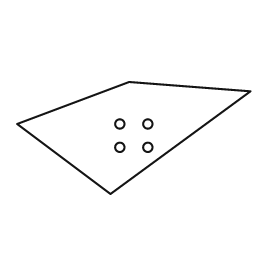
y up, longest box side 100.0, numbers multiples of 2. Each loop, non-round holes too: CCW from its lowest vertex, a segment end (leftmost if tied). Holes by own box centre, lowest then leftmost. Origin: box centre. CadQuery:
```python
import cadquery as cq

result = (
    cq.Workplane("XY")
    .moveTo(-10.0, -24.0)
    .lineTo(50.0, 20.0)
    .lineTo(-2.0, 24.0)
    .lineTo(-50.0, 6.0)
    .close()
    .moveTo(-6.0, -4.0)
    .circle(2.0)
    .moveTo(6.0, -4.0)
    .circle(2.0)
    .moveTo(-6.0, 6.0)
    .circle(2.0)
    .moveTo(6.0, 6.0)
    .circle(2.0)
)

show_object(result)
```